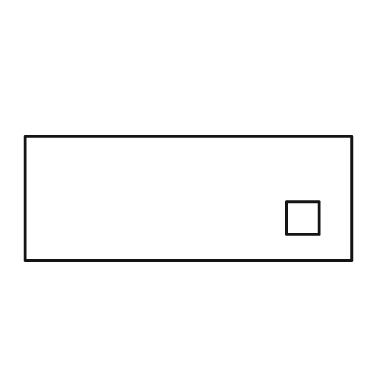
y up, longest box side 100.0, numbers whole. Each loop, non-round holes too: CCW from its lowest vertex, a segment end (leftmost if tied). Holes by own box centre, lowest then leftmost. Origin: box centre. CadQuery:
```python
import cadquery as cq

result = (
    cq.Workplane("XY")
    .moveTo(-50.0, -19.0)
    .lineTo(50.0, -19.0)
    .lineTo(50.0, 19.0)
    .lineTo(-50.0, 19.0)
    .close()
    .moveTo(30.0, -11.0)
    .lineTo(40.0, -11.0)
    .lineTo(40.0, -1.0)
    .lineTo(30.0, -1.0)
    .close()
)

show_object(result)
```